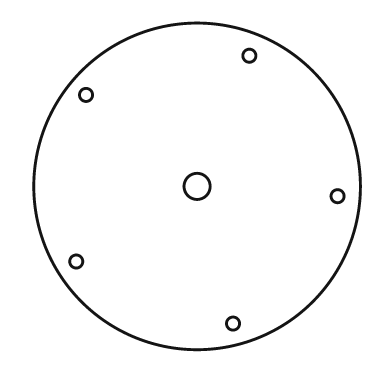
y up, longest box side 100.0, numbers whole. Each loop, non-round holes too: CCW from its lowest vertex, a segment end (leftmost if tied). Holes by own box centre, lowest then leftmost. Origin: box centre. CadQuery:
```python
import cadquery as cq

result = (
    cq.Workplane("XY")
    .moveTo(0.0, 0.0)
    .circle(50.0)
    .moveTo(11.0, -42.0)
    .circle(2.0)
    .moveTo(-37.0, -23.0)
    .circle(2.0)
    .moveTo(43.0, -3.0)
    .circle(2.0)
    .moveTo(0.0, 0.0)
    .circle(4.0)
    .moveTo(-34.0, 28.0)
    .circle(2.0)
    .moveTo(16.0, 40.0)
    .circle(2.0)
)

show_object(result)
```